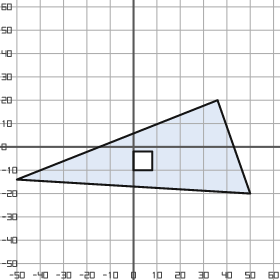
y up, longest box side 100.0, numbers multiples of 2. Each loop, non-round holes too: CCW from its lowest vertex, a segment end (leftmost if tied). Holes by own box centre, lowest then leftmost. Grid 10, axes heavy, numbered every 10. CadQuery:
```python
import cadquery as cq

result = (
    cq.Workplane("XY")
    .moveTo(50.0, -20.0)
    .lineTo(36.0, 20.0)
    .lineTo(-50.0, -14.0)
    .close()
    .moveTo(0.0, -10.0)
    .lineTo(8.0, -10.0)
    .lineTo(8.0, -2.0)
    .lineTo(0.0, -2.0)
    .close()
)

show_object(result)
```